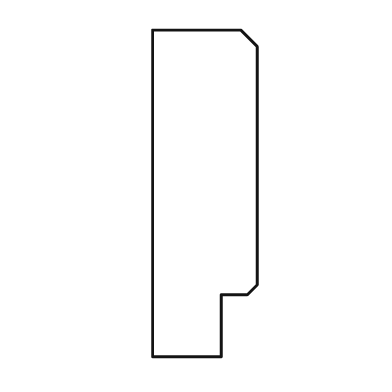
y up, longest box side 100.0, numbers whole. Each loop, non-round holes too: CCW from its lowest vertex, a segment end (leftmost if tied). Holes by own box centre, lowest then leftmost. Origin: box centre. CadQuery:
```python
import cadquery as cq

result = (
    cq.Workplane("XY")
    .moveTo(-16.0, -50.0)
    .lineTo(5.0, -50.0)
    .lineTo(5.0, -31.0)
    .lineTo(13.0, -31.0)
    .lineTo(16.0, -28.0)
    .lineTo(16.0, 45.0)
    .lineTo(11.0, 50.0)
    .lineTo(-16.0, 50.0)
    .close()
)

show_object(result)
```